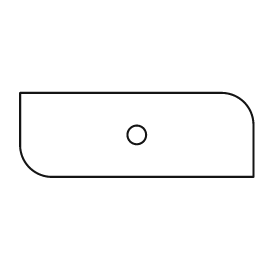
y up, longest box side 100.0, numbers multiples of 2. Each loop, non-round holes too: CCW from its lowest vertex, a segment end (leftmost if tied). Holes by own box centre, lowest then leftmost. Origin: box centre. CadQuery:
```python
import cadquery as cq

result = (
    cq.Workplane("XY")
    .moveTo(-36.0, -18.0)
    .lineTo(50.0, -18.0)
    .lineTo(50.0, 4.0)
    .threePointArc((46.0, 14.0), (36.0, 18.0))
    .lineTo(-50.0, 18.0)
    .lineTo(-50.0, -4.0)
    .threePointArc((-46.0, -14.0), (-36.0, -18.0))
    .close()
    .moveTo(0.0, 0.0)
    .circle(4.0)
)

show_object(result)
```